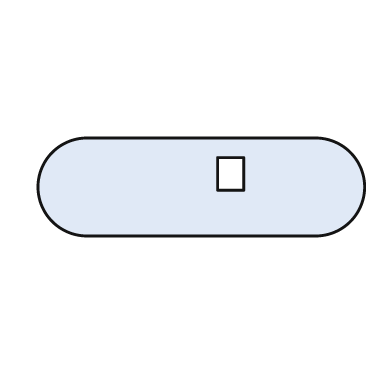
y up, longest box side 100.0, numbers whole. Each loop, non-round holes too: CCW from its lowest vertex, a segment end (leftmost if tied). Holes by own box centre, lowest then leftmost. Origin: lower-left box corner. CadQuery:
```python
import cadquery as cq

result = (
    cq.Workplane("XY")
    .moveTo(15.0, 0.0)
    .lineTo(85.0, 0.0)
    .threePointArc((100.0, 15.0), (85.0, 30.0))
    .lineTo(15.0, 30.0)
    .threePointArc((0.0, 15.0), (15.0, 0.0))
    .close()
    .moveTo(55.0, 14.0)
    .lineTo(63.0, 14.0)
    .lineTo(63.0, 24.0)
    .lineTo(55.0, 24.0)
    .close()
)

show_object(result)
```